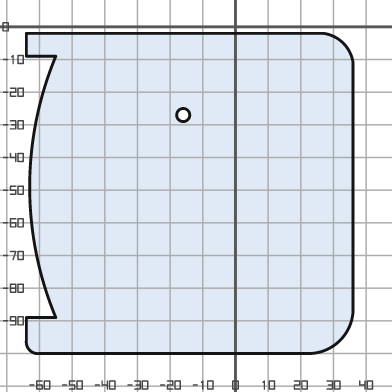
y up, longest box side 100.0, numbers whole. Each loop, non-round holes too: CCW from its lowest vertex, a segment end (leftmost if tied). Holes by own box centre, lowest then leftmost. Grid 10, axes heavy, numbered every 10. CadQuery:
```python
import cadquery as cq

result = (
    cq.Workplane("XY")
    .moveTo(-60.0, -100.0)
    .lineTo(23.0, -100.0)
    .threePointArc((32.0, -96.0), (36.0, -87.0))
    .lineTo(36.0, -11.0)
    .threePointArc((33.0, -5.0), (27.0, -2.0))
    .lineTo(-64.0, -2.0)
    .lineTo(-64.0, -9.0)
    .lineTo(-55.0, -9.0)
    .threePointArc((-63.0, -49.0), (-55.0, -89.0))
    .lineTo(-64.0, -89.0)
    .lineTo(-64.0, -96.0)
    .threePointArc((-63.0, -99.0), (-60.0, -100.0))
    .close()
    .moveTo(-16.0, -27.0)
    .circle(2.0)
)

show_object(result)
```